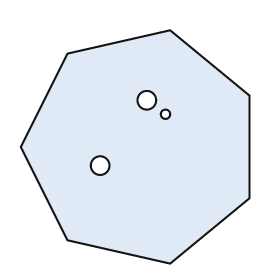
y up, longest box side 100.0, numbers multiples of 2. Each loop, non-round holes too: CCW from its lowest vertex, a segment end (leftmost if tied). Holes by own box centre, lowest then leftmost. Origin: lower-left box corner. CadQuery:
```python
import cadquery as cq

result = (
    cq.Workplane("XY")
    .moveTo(64.0, 0.0)
    .lineTo(98.0, 28.0)
    .lineTo(98.0, 72.0)
    .lineTo(64.0, 100.0)
    .lineTo(20.0, 90.0)
    .lineTo(0.0, 50.0)
    .lineTo(20.0, 10.0)
    .close()
    .moveTo(34.0, 42.0)
    .circle(4.0)
    .moveTo(62.0, 64.0)
    .circle(2.0)
    .moveTo(54.0, 70.0)
    .circle(4.0)
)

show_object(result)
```